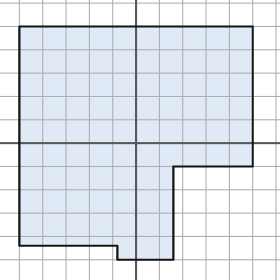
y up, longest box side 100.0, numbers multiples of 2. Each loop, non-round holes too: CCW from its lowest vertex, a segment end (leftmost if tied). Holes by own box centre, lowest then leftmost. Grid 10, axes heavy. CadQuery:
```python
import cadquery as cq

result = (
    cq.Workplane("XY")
    .moveTo(-8.0, -50.0)
    .lineTo(16.0, -50.0)
    .lineTo(16.0, -10.0)
    .lineTo(50.0, -10.0)
    .lineTo(50.0, 50.0)
    .lineTo(-50.0, 50.0)
    .lineTo(-50.0, -44.0)
    .lineTo(-8.0, -44.0)
    .close()
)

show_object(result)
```